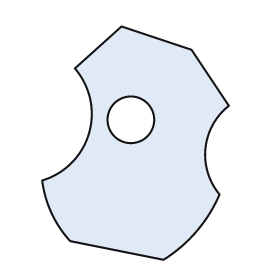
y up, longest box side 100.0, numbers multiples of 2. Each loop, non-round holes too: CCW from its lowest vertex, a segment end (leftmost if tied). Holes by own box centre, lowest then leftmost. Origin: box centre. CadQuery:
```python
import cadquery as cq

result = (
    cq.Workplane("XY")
    .moveTo(12.0, -50.0)
    .threePointArc((26.0, -38.0), (36.0, -22.0))
    .threePointArc((30.0, -2.0), (40.0, 16.0))
    .lineTo(24.0, 40.0)
    .lineTo(-6.0, 50.0)
    .lineTo(-26.0, 32.0)
    .threePointArc((-20.0, 4.0), (-40.0, -16.0))
    .threePointArc((-36.0, -30.0), (-28.0, -42.0))
    .close()
    .moveTo(-2.0, 10.0)
    .circle(10.0)
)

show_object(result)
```